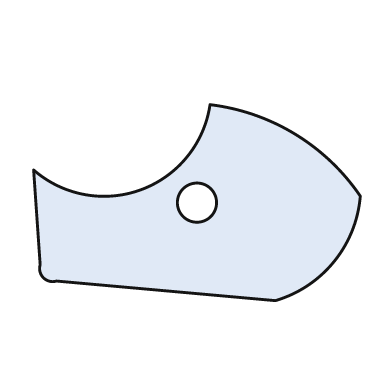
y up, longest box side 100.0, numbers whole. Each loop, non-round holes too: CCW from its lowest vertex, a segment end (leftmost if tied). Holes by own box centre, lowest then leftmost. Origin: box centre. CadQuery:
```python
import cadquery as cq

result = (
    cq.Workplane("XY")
    .moveTo(24.0, -30.0)
    .threePointArc((42.0, -18.0), (50.0, 2.0))
    .threePointArc((30.0, 21.0), (4.0, 30.0))
    .threePointArc((-17.0, 4.0), (-50.0, 10.0))
    .lineTo(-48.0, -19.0)
    .threePointArc((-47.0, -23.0), (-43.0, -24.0))
    .close()
    .moveTo(0.0, 0.0)
    .circle(6.0)
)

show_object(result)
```